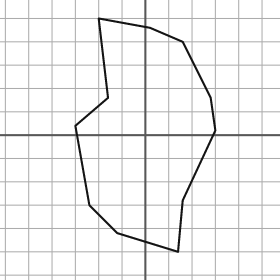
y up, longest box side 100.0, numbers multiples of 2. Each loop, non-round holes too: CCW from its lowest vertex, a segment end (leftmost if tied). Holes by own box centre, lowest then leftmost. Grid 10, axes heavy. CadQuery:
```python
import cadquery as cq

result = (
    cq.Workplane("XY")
    .moveTo(14.0, -50.0)
    .lineTo(16.0, -28.0)
    .lineTo(30.0, 2.0)
    .lineTo(28.0, 16.0)
    .lineTo(16.0, 40.0)
    .lineTo(2.0, 46.0)
    .lineTo(-20.0, 50.0)
    .lineTo(-16.0, 16.0)
    .lineTo(-30.0, 4.0)
    .lineTo(-24.0, -30.0)
    .lineTo(-12.0, -42.0)
    .close()
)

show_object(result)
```